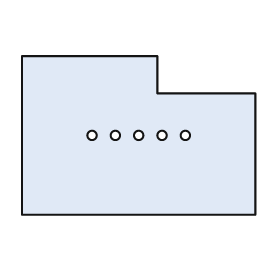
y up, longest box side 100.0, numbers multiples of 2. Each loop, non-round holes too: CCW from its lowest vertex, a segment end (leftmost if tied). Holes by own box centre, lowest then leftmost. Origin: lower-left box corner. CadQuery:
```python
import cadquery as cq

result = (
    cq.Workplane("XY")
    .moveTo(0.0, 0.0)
    .lineTo(100.0, 0.0)
    .lineTo(100.0, 52.0)
    .lineTo(58.0, 52.0)
    .lineTo(58.0, 68.0)
    .lineTo(0.0, 68.0)
    .close()
    .moveTo(30.0, 34.0)
    .circle(2.0)
    .moveTo(40.0, 34.0)
    .circle(2.0)
    .moveTo(50.0, 34.0)
    .circle(2.0)
    .moveTo(60.0, 34.0)
    .circle(2.0)
    .moveTo(70.0, 34.0)
    .circle(2.0)
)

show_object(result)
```